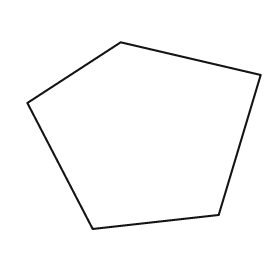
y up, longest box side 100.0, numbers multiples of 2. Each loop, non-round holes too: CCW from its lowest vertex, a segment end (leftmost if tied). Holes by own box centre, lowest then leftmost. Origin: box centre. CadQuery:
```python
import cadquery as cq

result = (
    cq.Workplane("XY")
    .moveTo(-22.0, -40.0)
    .lineTo(32.0, -34.0)
    .lineTo(50.0, 26.0)
    .lineTo(-10.0, 40.0)
    .lineTo(-50.0, 14.0)
    .close()
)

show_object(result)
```